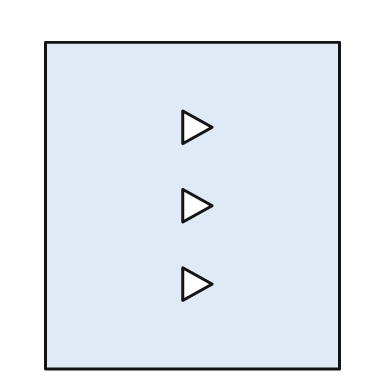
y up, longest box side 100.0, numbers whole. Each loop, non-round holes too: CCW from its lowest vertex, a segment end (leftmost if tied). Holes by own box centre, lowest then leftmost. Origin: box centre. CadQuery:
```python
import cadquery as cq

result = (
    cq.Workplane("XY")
    .moveTo(-45.0, -50.0)
    .lineTo(45.0, -50.0)
    .lineTo(45.0, 50.0)
    .lineTo(-45.0, 50.0)
    .close()
    .moveTo(-3.0, -29.0)
    .lineTo(6.0, -24.0)
    .lineTo(-3.0, -19.0)
    .close()
    .moveTo(-3.0, -5.0)
    .lineTo(6.0, 0.0)
    .lineTo(-3.0, 5.0)
    .close()
    .moveTo(-3.0, 19.0)
    .lineTo(6.0, 24.0)
    .lineTo(-3.0, 29.0)
    .close()
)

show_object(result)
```